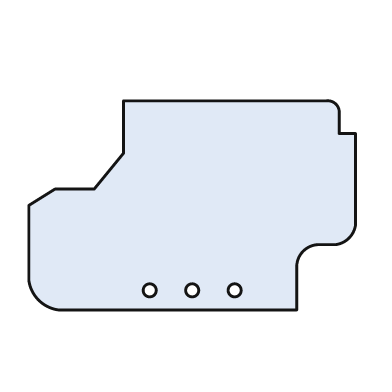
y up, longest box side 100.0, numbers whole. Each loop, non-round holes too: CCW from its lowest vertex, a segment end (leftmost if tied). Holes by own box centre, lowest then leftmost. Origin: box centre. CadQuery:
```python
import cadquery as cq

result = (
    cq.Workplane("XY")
    .moveTo(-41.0, -32.0)
    .lineTo(32.0, -32.0)
    .lineTo(32.0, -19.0)
    .threePointArc((34.0, -14.0), (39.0, -12.0))
    .lineTo(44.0, -12.0)
    .threePointArc((48.0, -10.0), (50.0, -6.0))
    .lineTo(50.0, 22.0)
    .lineTo(45.0, 22.0)
    .lineTo(45.0, 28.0)
    .threePointArc((44.0, 31.0), (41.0, 32.0))
    .lineTo(-21.0, 32.0)
    .lineTo(-21.0, 16.0)
    .lineTo(-30.0, 5.0)
    .lineTo(-42.0, 5.0)
    .lineTo(-50.0, 0.0)
    .lineTo(-50.0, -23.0)
    .threePointArc((-47.0, -29.0), (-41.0, -32.0))
    .close()
    .moveTo(-13.0, -26.0)
    .circle(2.0)
    .moveTo(0.0, -26.0)
    .circle(2.0)
    .moveTo(13.0, -26.0)
    .circle(2.0)
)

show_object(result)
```